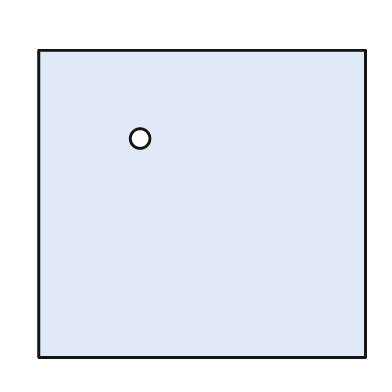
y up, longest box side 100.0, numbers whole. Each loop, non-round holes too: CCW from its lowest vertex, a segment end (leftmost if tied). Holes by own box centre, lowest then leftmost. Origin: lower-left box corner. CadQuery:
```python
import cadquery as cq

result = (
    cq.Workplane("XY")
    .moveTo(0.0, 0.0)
    .lineTo(100.0, 0.0)
    .lineTo(100.0, 94.0)
    .lineTo(0.0, 94.0)
    .close()
    .moveTo(31.0, 67.0)
    .circle(3.0)
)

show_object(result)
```